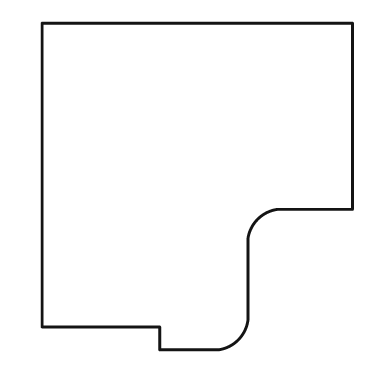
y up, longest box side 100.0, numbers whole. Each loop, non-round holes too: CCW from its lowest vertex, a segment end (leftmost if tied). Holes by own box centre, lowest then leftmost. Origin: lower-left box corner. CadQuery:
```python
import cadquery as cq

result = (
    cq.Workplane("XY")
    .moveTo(36.0, 0.0)
    .lineTo(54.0, 0.0)
    .threePointArc((60.0, 3.0), (63.0, 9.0))
    .lineTo(63.0, 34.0)
    .threePointArc((66.0, 40.0), (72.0, 43.0))
    .lineTo(95.0, 43.0)
    .lineTo(95.0, 100.0)
    .lineTo(0.0, 100.0)
    .lineTo(0.0, 7.0)
    .lineTo(36.0, 7.0)
    .close()
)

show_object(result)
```